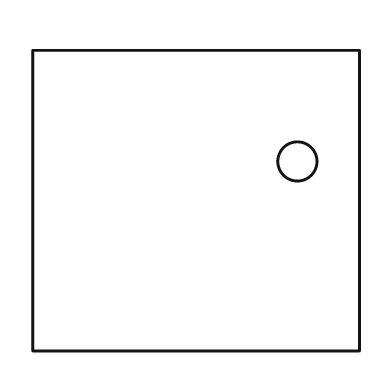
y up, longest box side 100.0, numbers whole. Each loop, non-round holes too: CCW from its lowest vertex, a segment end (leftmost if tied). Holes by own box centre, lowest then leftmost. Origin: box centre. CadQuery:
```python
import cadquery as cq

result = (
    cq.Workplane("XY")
    .moveTo(-50.0, -46.0)
    .lineTo(50.0, -46.0)
    .lineTo(50.0, 46.0)
    .lineTo(-50.0, 46.0)
    .close()
    .moveTo(31.0, 12.0)
    .circle(6.0)
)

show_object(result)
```